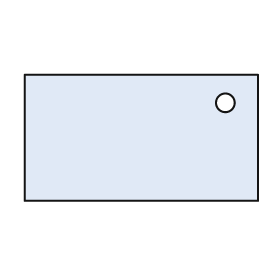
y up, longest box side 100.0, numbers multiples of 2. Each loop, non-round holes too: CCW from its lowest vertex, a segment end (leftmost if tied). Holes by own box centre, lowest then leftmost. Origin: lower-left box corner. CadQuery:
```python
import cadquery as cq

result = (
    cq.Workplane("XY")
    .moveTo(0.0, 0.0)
    .lineTo(100.0, 0.0)
    .lineTo(100.0, 54.0)
    .lineTo(0.0, 54.0)
    .close()
    .moveTo(86.0, 42.0)
    .circle(4.0)
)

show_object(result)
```